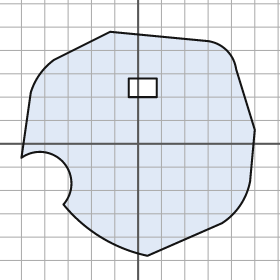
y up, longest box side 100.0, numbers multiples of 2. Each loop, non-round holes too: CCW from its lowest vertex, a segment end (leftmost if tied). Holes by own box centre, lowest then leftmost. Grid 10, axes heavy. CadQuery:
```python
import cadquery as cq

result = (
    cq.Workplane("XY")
    .moveTo(4.0, -48.0)
    .lineTo(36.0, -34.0)
    .threePointArc((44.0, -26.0), (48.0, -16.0))
    .lineTo(50.0, 6.0)
    .lineTo(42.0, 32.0)
    .threePointArc((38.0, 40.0), (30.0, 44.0))
    .lineTo(-12.0, 48.0)
    .lineTo(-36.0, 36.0)
    .threePointArc((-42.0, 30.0), (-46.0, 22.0))
    .lineTo(-50.0, -6.0)
    .threePointArc((-32.0, -8.0), (-32.0, -26.0))
    .threePointArc((-16.0, -40.0), (4.0, -48.0))
    .close()
    .moveTo(-4.0, 20.0)
    .lineTo(8.0, 20.0)
    .lineTo(8.0, 28.0)
    .lineTo(-4.0, 28.0)
    .close()
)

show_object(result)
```